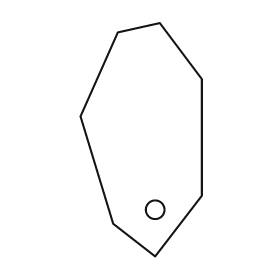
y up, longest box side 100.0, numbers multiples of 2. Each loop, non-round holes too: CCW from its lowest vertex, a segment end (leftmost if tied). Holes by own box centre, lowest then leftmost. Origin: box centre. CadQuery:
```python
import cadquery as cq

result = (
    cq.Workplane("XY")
    .moveTo(6.0, -50.0)
    .lineTo(26.0, -24.0)
    .lineTo(26.0, 26.0)
    .lineTo(8.0, 50.0)
    .lineTo(-10.0, 46.0)
    .lineTo(-26.0, 10.0)
    .lineTo(-12.0, -36.0)
    .close()
    .moveTo(6.0, -30.0)
    .circle(4.0)
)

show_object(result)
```